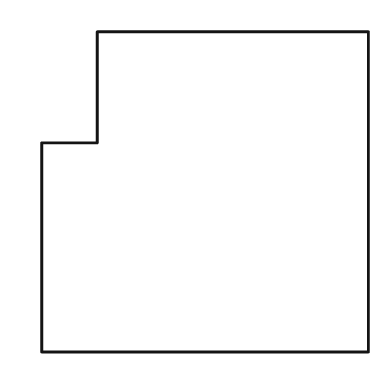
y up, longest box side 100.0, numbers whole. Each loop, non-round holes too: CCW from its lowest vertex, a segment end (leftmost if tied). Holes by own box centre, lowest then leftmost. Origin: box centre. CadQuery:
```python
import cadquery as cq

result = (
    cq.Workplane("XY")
    .moveTo(-50.0, -49.0)
    .lineTo(50.0, -49.0)
    .lineTo(50.0, 49.0)
    .lineTo(-33.0, 49.0)
    .lineTo(-33.0, 15.0)
    .lineTo(-50.0, 15.0)
    .close()
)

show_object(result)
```